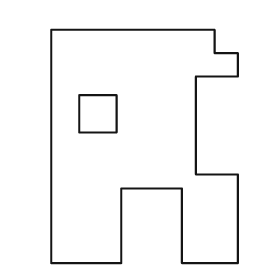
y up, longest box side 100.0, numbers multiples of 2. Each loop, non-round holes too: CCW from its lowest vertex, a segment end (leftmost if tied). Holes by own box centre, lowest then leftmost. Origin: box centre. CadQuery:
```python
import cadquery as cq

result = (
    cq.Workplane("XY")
    .moveTo(-40.0, -50.0)
    .lineTo(-10.0, -50.0)
    .lineTo(-10.0, -18.0)
    .lineTo(16.0, -18.0)
    .lineTo(16.0, -50.0)
    .lineTo(40.0, -50.0)
    .lineTo(40.0, -12.0)
    .lineTo(22.0, -12.0)
    .lineTo(22.0, 30.0)
    .lineTo(40.0, 30.0)
    .lineTo(40.0, 40.0)
    .lineTo(30.0, 40.0)
    .lineTo(30.0, 50.0)
    .lineTo(-40.0, 50.0)
    .close()
    .moveTo(-28.0, 6.0)
    .lineTo(-12.0, 6.0)
    .lineTo(-12.0, 22.0)
    .lineTo(-28.0, 22.0)
    .close()
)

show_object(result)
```